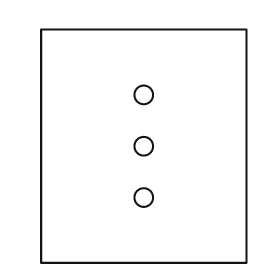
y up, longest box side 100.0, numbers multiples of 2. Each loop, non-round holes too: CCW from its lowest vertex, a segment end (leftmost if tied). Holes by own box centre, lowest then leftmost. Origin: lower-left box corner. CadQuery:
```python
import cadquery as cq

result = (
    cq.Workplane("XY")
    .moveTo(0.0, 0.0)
    .lineTo(88.0, 0.0)
    .lineTo(88.0, 100.0)
    .lineTo(0.0, 100.0)
    .close()
    .moveTo(44.0, 28.0)
    .circle(4.0)
    .moveTo(44.0, 50.0)
    .circle(4.0)
    .moveTo(44.0, 72.0)
    .circle(4.0)
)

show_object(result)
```